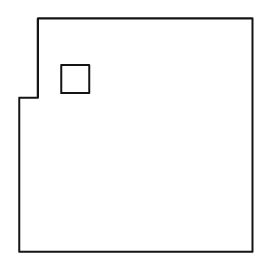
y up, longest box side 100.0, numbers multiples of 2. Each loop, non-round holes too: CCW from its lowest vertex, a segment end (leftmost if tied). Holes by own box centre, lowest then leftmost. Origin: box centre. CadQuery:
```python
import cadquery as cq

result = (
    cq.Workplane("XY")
    .moveTo(-50.0, -50.0)
    .lineTo(50.0, -50.0)
    .lineTo(50.0, 50.0)
    .lineTo(-42.0, 50.0)
    .lineTo(-42.0, 16.0)
    .lineTo(-50.0, 16.0)
    .close()
    .moveTo(-32.0, 18.0)
    .lineTo(-20.0, 18.0)
    .lineTo(-20.0, 30.0)
    .lineTo(-32.0, 30.0)
    .close()
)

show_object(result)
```